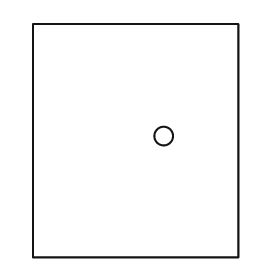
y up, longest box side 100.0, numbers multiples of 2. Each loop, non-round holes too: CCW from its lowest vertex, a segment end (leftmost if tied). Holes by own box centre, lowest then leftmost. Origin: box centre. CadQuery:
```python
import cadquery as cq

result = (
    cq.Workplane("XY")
    .moveTo(-44.0, -50.0)
    .lineTo(44.0, -50.0)
    .lineTo(44.0, 50.0)
    .lineTo(-44.0, 50.0)
    .close()
    .moveTo(12.0, 2.0)
    .circle(4.0)
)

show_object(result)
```